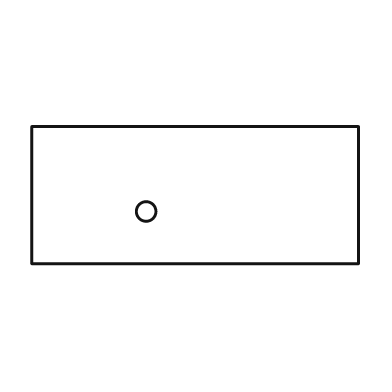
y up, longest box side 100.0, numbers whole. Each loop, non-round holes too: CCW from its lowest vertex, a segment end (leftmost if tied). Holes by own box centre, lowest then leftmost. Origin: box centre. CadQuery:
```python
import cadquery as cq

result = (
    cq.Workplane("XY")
    .moveTo(-50.0, -21.0)
    .lineTo(50.0, -21.0)
    .lineTo(50.0, 21.0)
    .lineTo(-50.0, 21.0)
    .close()
    .moveTo(-15.0, -5.0)
    .circle(3.0)
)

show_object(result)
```